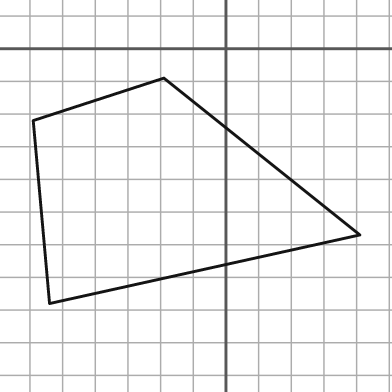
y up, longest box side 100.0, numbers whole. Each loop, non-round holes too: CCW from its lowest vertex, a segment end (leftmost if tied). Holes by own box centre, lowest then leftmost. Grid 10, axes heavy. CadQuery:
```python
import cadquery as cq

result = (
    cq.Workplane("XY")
    .moveTo(-54.0, -78.0)
    .lineTo(41.0, -57.0)
    .lineTo(-19.0, -9.0)
    .lineTo(-59.0, -22.0)
    .close()
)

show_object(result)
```